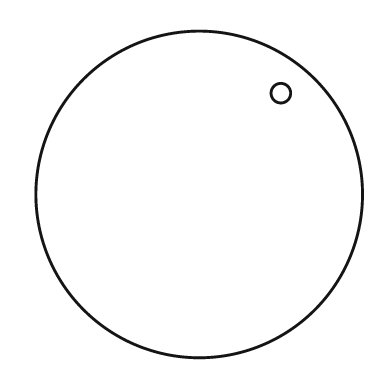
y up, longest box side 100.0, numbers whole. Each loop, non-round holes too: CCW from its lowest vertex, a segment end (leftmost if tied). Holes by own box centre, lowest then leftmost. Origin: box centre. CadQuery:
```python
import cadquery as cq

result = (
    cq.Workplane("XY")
    .moveTo(0.0, 0.0)
    .circle(50.0)
    .moveTo(25.0, 31.0)
    .circle(3.0)
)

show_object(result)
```